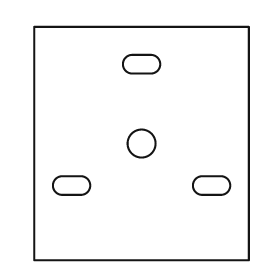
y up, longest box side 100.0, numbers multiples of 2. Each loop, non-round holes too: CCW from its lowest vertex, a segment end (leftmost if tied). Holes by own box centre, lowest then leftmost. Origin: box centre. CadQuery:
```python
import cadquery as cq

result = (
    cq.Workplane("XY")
    .moveTo(-46.0, -50.0)
    .lineTo(46.0, -50.0)
    .lineTo(46.0, 50.0)
    .lineTo(-46.0, 50.0)
    .close()
    .moveTo(-34.0, -22.0)
    .lineTo(-26.0, -22.0)
    .threePointArc((-22.0, -18.0), (-26.0, -14.0))
    .lineTo(-34.0, -14.0)
    .threePointArc((-38.0, -18.0), (-34.0, -22.0))
    .close()
    .moveTo(26.0, -22.0)
    .lineTo(34.0, -22.0)
    .threePointArc((38.0, -18.0), (34.0, -14.0))
    .lineTo(26.0, -14.0)
    .threePointArc((22.0, -18.0), (26.0, -22.0))
    .close()
    .moveTo(0.0, 0.0)
    .circle(6.0)
    .moveTo(-4.0, 30.0)
    .lineTo(4.0, 30.0)
    .threePointArc((8.0, 34.0), (4.0, 38.0))
    .lineTo(-4.0, 38.0)
    .threePointArc((-8.0, 34.0), (-4.0, 30.0))
    .close()
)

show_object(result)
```